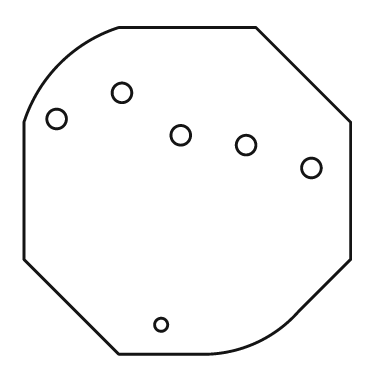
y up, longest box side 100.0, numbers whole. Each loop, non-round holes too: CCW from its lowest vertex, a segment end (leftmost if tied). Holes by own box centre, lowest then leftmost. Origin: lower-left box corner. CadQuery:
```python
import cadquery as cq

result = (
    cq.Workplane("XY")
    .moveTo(29.0, 0.0)
    .lineTo(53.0, 0.0)
    .threePointArc((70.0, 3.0), (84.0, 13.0))
    .lineTo(100.0, 29.0)
    .lineTo(100.0, 71.0)
    .lineTo(71.0, 100.0)
    .lineTo(29.0, 100.0)
    .threePointArc((11.0, 89.0), (0.0, 71.0))
    .lineTo(0.0, 29.0)
    .close()
    .moveTo(42.0, 9.0)
    .circle(2.0)
    .moveTo(88.0, 57.0)
    .circle(3.0)
    .moveTo(68.0, 64.0)
    .circle(3.0)
    .moveTo(48.0, 67.0)
    .circle(3.0)
    .moveTo(10.0, 72.0)
    .circle(3.0)
    .moveTo(30.0, 80.0)
    .circle(3.0)
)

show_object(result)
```